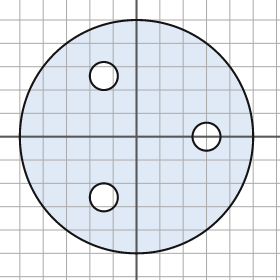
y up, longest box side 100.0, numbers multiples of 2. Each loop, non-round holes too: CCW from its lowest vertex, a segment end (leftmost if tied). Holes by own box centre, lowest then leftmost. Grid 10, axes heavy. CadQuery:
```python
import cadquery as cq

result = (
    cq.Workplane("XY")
    .moveTo(0.0, 0.0)
    .circle(50.0)
    .moveTo(-14.0, -26.0)
    .circle(6.0)
    .moveTo(30.0, 0.0)
    .circle(6.0)
    .moveTo(-14.0, 26.0)
    .circle(6.0)
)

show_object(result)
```